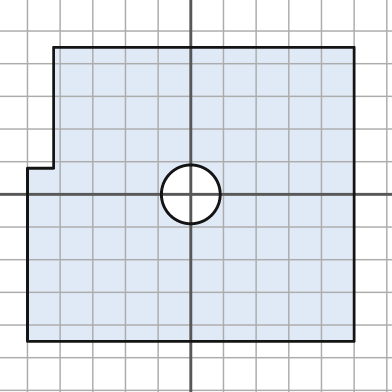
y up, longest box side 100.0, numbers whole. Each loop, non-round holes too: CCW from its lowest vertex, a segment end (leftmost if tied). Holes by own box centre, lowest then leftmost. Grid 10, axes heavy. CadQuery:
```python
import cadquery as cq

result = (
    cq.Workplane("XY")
    .moveTo(-50.0, -45.0)
    .lineTo(50.0, -45.0)
    .lineTo(50.0, 45.0)
    .lineTo(-42.0, 45.0)
    .lineTo(-42.0, 8.0)
    .lineTo(-50.0, 8.0)
    .close()
    .moveTo(0.0, 0.0)
    .circle(9.0)
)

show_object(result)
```